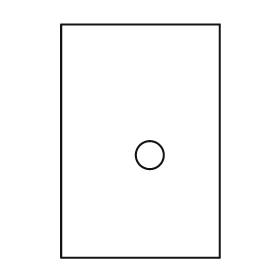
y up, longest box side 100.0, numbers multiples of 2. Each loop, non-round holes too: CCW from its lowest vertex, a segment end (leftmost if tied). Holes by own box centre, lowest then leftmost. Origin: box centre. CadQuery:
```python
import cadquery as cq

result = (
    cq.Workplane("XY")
    .moveTo(-34.0, -50.0)
    .lineTo(34.0, -50.0)
    .lineTo(34.0, 50.0)
    .lineTo(-34.0, 50.0)
    .close()
    .moveTo(4.0, -6.0)
    .circle(6.0)
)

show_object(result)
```